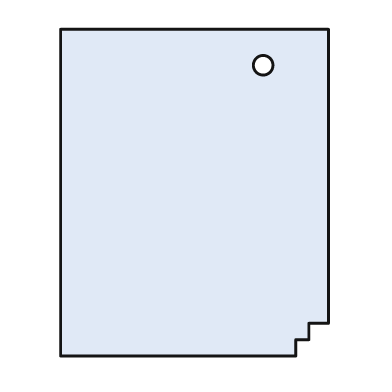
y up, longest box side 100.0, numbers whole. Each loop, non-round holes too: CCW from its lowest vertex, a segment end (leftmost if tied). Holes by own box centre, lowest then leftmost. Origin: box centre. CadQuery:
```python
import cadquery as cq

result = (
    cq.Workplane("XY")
    .moveTo(-41.0, -50.0)
    .lineTo(31.0, -50.0)
    .lineTo(31.0, -45.0)
    .lineTo(35.0, -45.0)
    .lineTo(35.0, -40.0)
    .lineTo(41.0, -40.0)
    .lineTo(41.0, 50.0)
    .lineTo(-41.0, 50.0)
    .close()
    .moveTo(21.0, 39.0)
    .circle(3.0)
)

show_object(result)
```